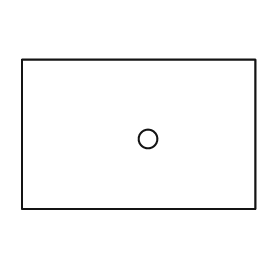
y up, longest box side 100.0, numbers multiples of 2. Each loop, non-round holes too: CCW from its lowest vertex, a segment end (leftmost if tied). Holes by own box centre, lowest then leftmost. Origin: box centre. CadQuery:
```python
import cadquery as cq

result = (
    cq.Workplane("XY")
    .moveTo(-50.0, -32.0)
    .lineTo(50.0, -32.0)
    .lineTo(50.0, 32.0)
    .lineTo(-50.0, 32.0)
    .close()
    .moveTo(4.0, -2.0)
    .circle(4.0)
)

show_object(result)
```